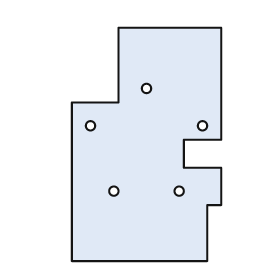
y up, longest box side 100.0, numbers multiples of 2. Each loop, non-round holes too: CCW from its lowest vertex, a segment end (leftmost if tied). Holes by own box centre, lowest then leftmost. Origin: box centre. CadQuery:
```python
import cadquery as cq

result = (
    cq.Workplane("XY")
    .moveTo(-32.0, -50.0)
    .lineTo(26.0, -50.0)
    .lineTo(26.0, -26.0)
    .lineTo(32.0, -26.0)
    .lineTo(32.0, -10.0)
    .lineTo(16.0, -10.0)
    .lineTo(16.0, 2.0)
    .lineTo(32.0, 2.0)
    .lineTo(32.0, 50.0)
    .lineTo(-12.0, 50.0)
    .lineTo(-12.0, 18.0)
    .lineTo(-32.0, 18.0)
    .close()
    .moveTo(-14.0, -20.0)
    .circle(2.0)
    .moveTo(14.0, -20.0)
    .circle(2.0)
    .moveTo(-24.0, 8.0)
    .circle(2.0)
    .moveTo(24.0, 8.0)
    .circle(2.0)
    .moveTo(0.0, 24.0)
    .circle(2.0)
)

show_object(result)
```